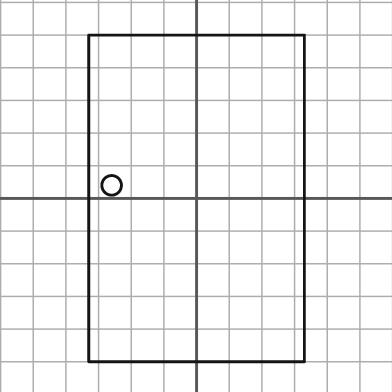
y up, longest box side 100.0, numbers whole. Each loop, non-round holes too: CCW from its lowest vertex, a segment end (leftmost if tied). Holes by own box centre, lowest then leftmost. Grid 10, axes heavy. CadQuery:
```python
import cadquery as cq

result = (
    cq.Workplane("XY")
    .moveTo(-33.0, -50.0)
    .lineTo(33.0, -50.0)
    .lineTo(33.0, 50.0)
    .lineTo(-33.0, 50.0)
    .close()
    .moveTo(-26.0, 4.0)
    .circle(3.0)
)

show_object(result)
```